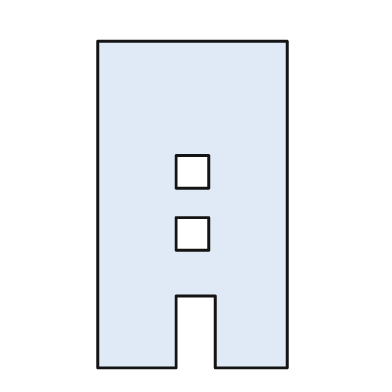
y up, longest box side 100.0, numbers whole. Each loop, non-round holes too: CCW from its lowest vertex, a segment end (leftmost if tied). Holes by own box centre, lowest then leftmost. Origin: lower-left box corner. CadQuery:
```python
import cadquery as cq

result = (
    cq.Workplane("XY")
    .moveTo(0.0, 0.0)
    .lineTo(24.0, 0.0)
    .lineTo(24.0, 22.0)
    .lineTo(36.0, 22.0)
    .lineTo(36.0, 0.0)
    .lineTo(58.0, 0.0)
    .lineTo(58.0, 100.0)
    .lineTo(0.0, 100.0)
    .close()
    .moveTo(24.0, 36.0)
    .lineTo(34.0, 36.0)
    .lineTo(34.0, 46.0)
    .lineTo(24.0, 46.0)
    .close()
    .moveTo(24.0, 55.0)
    .lineTo(34.0, 55.0)
    .lineTo(34.0, 65.0)
    .lineTo(24.0, 65.0)
    .close()
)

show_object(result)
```